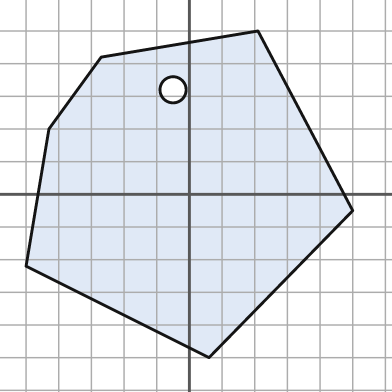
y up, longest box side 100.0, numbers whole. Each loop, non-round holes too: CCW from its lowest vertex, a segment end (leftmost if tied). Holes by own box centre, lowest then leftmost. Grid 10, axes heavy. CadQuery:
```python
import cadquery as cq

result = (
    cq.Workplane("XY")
    .moveTo(6.0, -50.0)
    .lineTo(50.0, -5.0)
    .lineTo(21.0, 50.0)
    .lineTo(-27.0, 42.0)
    .lineTo(-43.0, 20.0)
    .lineTo(-50.0, -22.0)
    .close()
    .moveTo(-5.0, 32.0)
    .circle(4.0)
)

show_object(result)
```